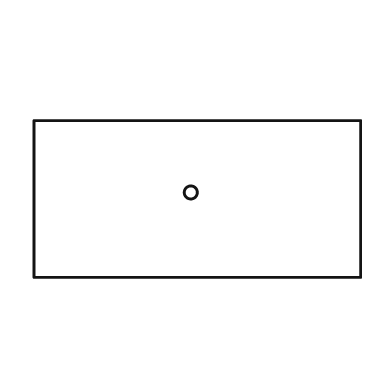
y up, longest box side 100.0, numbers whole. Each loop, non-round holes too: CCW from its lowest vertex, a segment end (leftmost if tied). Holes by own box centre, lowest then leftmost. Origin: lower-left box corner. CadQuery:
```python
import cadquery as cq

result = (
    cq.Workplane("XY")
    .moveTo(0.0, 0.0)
    .lineTo(100.0, 0.0)
    .lineTo(100.0, 48.0)
    .lineTo(0.0, 48.0)
    .close()
    .moveTo(48.0, 26.0)
    .circle(2.0)
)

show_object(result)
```